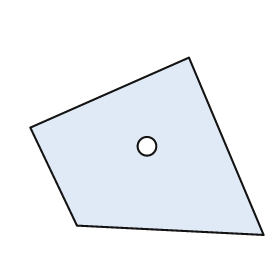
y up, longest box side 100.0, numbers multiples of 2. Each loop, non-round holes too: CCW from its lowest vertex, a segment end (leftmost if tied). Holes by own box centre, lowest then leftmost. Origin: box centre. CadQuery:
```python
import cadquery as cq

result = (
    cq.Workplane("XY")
    .moveTo(50.0, -38.0)
    .lineTo(18.0, 38.0)
    .lineTo(-50.0, 8.0)
    .lineTo(-30.0, -34.0)
    .close()
    .moveTo(0.0, 0.0)
    .circle(4.0)
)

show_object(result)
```